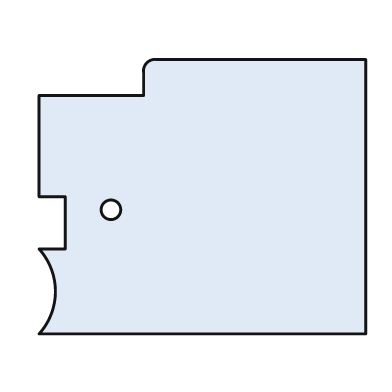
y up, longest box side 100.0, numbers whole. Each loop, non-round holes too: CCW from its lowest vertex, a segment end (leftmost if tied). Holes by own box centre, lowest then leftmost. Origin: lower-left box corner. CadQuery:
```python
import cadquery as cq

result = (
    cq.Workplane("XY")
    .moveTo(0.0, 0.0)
    .lineTo(100.0, 0.0)
    .lineTo(100.0, 84.0)
    .lineTo(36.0, 84.0)
    .threePointArc((33.0, 83.0), (32.0, 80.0))
    .lineTo(32.0, 73.0)
    .lineTo(0.0, 73.0)
    .lineTo(0.0, 42.0)
    .lineTo(8.0, 42.0)
    .lineTo(8.0, 26.0)
    .lineTo(0.0, 26.0)
    .threePointArc((5.0, 13.0), (0.0, 0.0))
    .close()
    .moveTo(22.0, 38.0)
    .circle(3.0)
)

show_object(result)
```